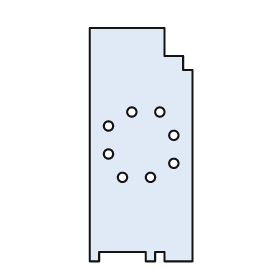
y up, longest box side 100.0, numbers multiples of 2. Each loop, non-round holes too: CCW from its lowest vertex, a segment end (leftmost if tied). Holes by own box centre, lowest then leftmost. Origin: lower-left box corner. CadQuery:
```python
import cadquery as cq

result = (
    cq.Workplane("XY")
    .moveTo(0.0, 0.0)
    .lineTo(4.0, 0.0)
    .lineTo(4.0, 4.0)
    .lineTo(24.0, 4.0)
    .lineTo(24.0, 0.0)
    .lineTo(28.0, 0.0)
    .lineTo(28.0, 4.0)
    .lineTo(32.0, 4.0)
    .lineTo(32.0, 0.0)
    .lineTo(44.0, 0.0)
    .lineTo(44.0, 82.0)
    .lineTo(40.0, 82.0)
    .lineTo(40.0, 88.0)
    .lineTo(32.0, 88.0)
    .lineTo(32.0, 100.0)
    .lineTo(0.0, 100.0)
    .close()
    .moveTo(14.0, 36.0)
    .circle(2.0)
    .moveTo(26.0, 36.0)
    .circle(2.0)
    .moveTo(36.0, 42.0)
    .circle(2.0)
    .moveTo(8.0, 46.0)
    .circle(2.0)
    .moveTo(36.0, 54.0)
    .circle(2.0)
    .moveTo(8.0, 58.0)
    .circle(2.0)
    .moveTo(18.0, 64.0)
    .circle(2.0)
    .moveTo(30.0, 64.0)
    .circle(2.0)
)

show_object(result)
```